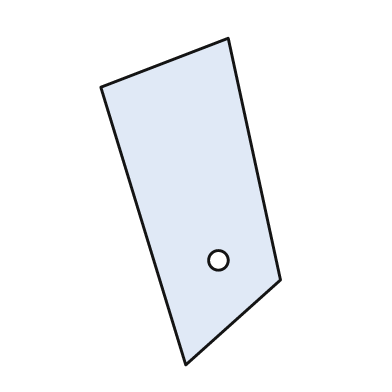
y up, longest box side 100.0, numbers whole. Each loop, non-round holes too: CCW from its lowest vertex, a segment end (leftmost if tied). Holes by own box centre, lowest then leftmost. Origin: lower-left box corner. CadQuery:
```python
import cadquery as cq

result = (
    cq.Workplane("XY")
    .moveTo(26.0, 0.0)
    .lineTo(55.0, 26.0)
    .lineTo(39.0, 100.0)
    .lineTo(0.0, 85.0)
    .close()
    .moveTo(36.0, 32.0)
    .circle(3.0)
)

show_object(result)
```